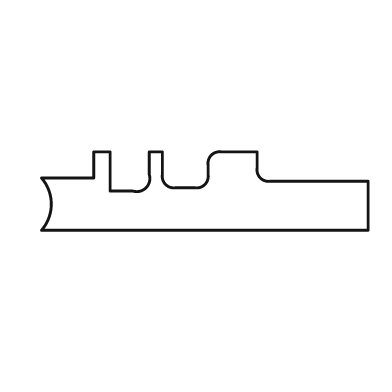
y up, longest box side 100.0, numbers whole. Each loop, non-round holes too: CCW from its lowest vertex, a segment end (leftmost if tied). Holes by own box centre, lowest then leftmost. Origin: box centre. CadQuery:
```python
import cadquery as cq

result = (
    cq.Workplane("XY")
    .moveTo(-50.0, -12.0)
    .lineTo(50.0, -12.0)
    .lineTo(50.0, 3.0)
    .lineTo(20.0, 3.0)
    .threePointArc((17.0, 4.0), (16.0, 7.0))
    .lineTo(16.0, 12.0)
    .lineTo(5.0, 12.0)
    .threePointArc((2.0, 11.0), (1.0, 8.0))
    .lineTo(1.0, 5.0)
    .threePointArc((0.0, 2.0), (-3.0, 1.0))
    .lineTo(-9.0, 1.0)
    .threePointArc((-12.0, 2.0), (-13.0, 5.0))
    .lineTo(-13.0, 12.0)
    .lineTo(-17.0, 12.0)
    .lineTo(-17.0, 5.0)
    .threePointArc((-18.0, 1.0), (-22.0, 0.0))
    .lineTo(-29.0, 0.0)
    .lineTo(-29.0, 12.0)
    .lineTo(-34.0, 12.0)
    .lineTo(-34.0, 4.0)
    .lineTo(-50.0, 4.0)
    .threePointArc((-47.0, -4.0), (-50.0, -12.0))
    .close()
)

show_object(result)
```